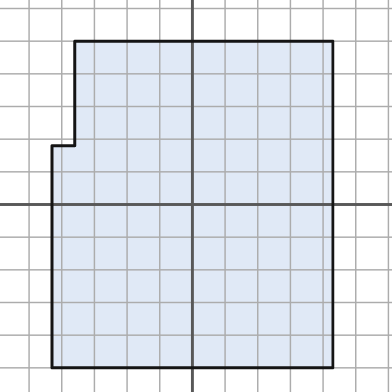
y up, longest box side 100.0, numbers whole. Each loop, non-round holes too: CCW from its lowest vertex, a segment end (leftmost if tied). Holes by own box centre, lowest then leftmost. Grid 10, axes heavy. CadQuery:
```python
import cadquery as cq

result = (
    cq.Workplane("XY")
    .moveTo(-43.0, -50.0)
    .lineTo(43.0, -50.0)
    .lineTo(43.0, 50.0)
    .lineTo(-36.0, 50.0)
    .lineTo(-36.0, 18.0)
    .lineTo(-43.0, 18.0)
    .close()
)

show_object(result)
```